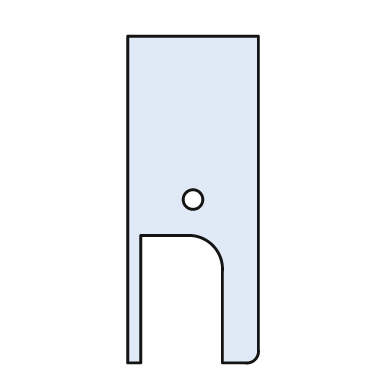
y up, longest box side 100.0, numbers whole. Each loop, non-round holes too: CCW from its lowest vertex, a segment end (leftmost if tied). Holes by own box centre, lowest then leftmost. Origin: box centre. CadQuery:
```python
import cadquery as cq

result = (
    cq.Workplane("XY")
    .moveTo(-20.0, -50.0)
    .lineTo(-16.0, -50.0)
    .lineTo(-16.0, -11.0)
    .lineTo(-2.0, -11.0)
    .threePointArc((6.0, -14.0), (9.0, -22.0))
    .lineTo(9.0, -50.0)
    .lineTo(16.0, -50.0)
    .threePointArc((19.0, -49.0), (20.0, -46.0))
    .lineTo(20.0, 50.0)
    .lineTo(-20.0, 50.0)
    .close()
    .moveTo(0.0, 0.0)
    .circle(3.0)
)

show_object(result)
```